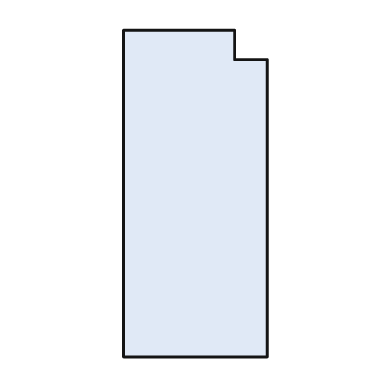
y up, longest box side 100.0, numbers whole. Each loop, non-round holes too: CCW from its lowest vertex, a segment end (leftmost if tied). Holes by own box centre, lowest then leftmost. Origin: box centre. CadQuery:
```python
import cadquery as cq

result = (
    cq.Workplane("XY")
    .moveTo(-22.0, -50.0)
    .lineTo(22.0, -50.0)
    .lineTo(22.0, 41.0)
    .lineTo(12.0, 41.0)
    .lineTo(12.0, 50.0)
    .lineTo(-22.0, 50.0)
    .close()
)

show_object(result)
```